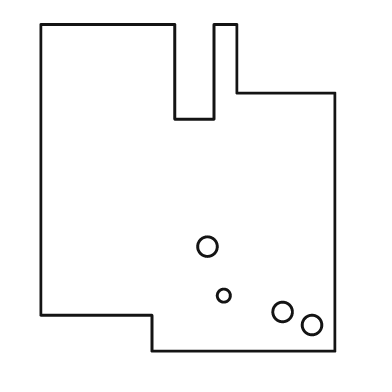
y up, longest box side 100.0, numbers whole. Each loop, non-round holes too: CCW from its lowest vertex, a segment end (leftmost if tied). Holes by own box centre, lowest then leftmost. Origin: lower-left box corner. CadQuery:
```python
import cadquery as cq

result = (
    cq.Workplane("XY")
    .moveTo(34.0, 0.0)
    .lineTo(90.0, 0.0)
    .lineTo(90.0, 79.0)
    .lineTo(60.0, 79.0)
    .lineTo(60.0, 100.0)
    .lineTo(53.0, 100.0)
    .lineTo(53.0, 71.0)
    .lineTo(41.0, 71.0)
    .lineTo(41.0, 100.0)
    .lineTo(0.0, 100.0)
    .lineTo(0.0, 11.0)
    .lineTo(34.0, 11.0)
    .close()
    .moveTo(83.0, 8.0)
    .circle(3.0)
    .moveTo(74.0, 12.0)
    .circle(3.0)
    .moveTo(56.0, 17.0)
    .circle(2.0)
    .moveTo(51.0, 32.0)
    .circle(3.0)
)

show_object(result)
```